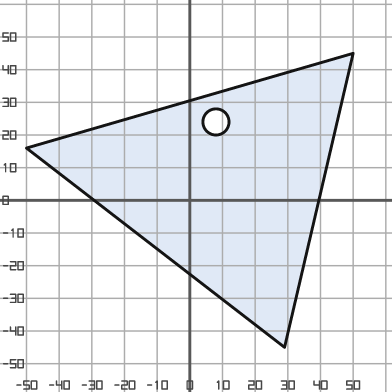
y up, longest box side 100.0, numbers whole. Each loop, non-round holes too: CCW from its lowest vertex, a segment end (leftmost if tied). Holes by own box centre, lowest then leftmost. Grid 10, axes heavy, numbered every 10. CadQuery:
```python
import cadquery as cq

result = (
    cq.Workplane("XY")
    .moveTo(29.0, -45.0)
    .lineTo(50.0, 45.0)
    .lineTo(-50.0, 16.0)
    .close()
    .moveTo(8.0, 24.0)
    .circle(4.0)
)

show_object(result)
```